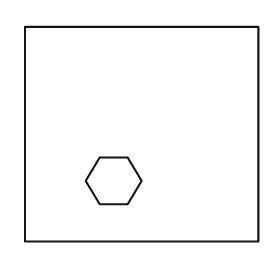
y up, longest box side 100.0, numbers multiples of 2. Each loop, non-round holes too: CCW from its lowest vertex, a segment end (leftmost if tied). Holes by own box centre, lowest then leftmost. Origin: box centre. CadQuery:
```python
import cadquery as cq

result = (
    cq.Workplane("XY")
    .moveTo(-50.0, -46.0)
    .lineTo(50.0, -46.0)
    .lineTo(50.0, 46.0)
    .lineTo(-50.0, 46.0)
    .close()
    .moveTo(-18.0, -30.0)
    .lineTo(-6.0, -30.0)
    .lineTo(0.0, -20.0)
    .lineTo(-6.0, -10.0)
    .lineTo(-18.0, -10.0)
    .lineTo(-24.0, -20.0)
    .close()
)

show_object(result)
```